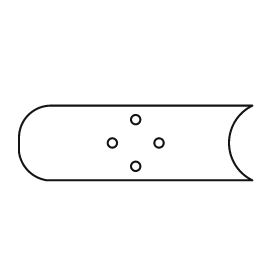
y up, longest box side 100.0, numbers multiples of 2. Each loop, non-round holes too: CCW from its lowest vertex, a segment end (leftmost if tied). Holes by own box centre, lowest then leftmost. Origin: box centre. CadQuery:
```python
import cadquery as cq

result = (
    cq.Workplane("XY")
    .moveTo(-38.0, -16.0)
    .lineTo(50.0, -16.0)
    .threePointArc((40.0, 0.0), (50.0, 16.0))
    .lineTo(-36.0, 16.0)
    .threePointArc((-46.0, 12.0), (-50.0, 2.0))
    .lineTo(-50.0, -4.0)
    .threePointArc((-46.0, -12.0), (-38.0, -16.0))
    .close()
    .moveTo(0.0, -10.0)
    .circle(2.0)
    .moveTo(-10.0, 0.0)
    .circle(2.0)
    .moveTo(10.0, 0.0)
    .circle(2.0)
    .moveTo(0.0, 10.0)
    .circle(2.0)
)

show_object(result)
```